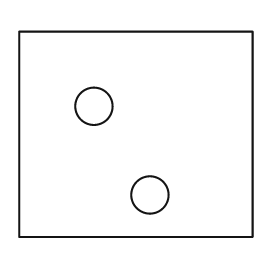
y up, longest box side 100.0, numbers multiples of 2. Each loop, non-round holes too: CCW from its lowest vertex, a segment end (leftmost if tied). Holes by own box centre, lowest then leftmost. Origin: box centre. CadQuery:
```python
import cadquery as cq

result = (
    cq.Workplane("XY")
    .moveTo(-50.0, -44.0)
    .lineTo(50.0, -44.0)
    .lineTo(50.0, 44.0)
    .lineTo(-50.0, 44.0)
    .close()
    .moveTo(6.0, -26.0)
    .circle(8.0)
    .moveTo(-18.0, 12.0)
    .circle(8.0)
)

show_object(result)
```